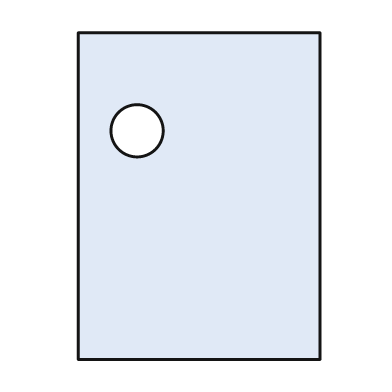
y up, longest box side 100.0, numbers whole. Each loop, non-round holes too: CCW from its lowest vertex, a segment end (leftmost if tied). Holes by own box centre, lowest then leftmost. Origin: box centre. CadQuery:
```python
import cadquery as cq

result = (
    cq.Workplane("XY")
    .moveTo(-37.0, -50.0)
    .lineTo(37.0, -50.0)
    .lineTo(37.0, 50.0)
    .lineTo(-37.0, 50.0)
    .close()
    .moveTo(-19.0, 20.0)
    .circle(8.0)
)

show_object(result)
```